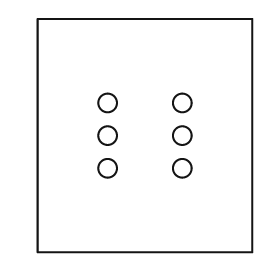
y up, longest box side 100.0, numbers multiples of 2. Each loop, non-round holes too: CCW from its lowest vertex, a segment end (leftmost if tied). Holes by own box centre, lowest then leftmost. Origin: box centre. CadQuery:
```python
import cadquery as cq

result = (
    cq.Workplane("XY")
    .moveTo(-46.0, -50.0)
    .lineTo(46.0, -50.0)
    .lineTo(46.0, 50.0)
    .lineTo(-46.0, 50.0)
    .close()
    .moveTo(-16.0, -14.0)
    .circle(4.0)
    .moveTo(16.0, -14.0)
    .circle(4.0)
    .moveTo(-16.0, 0.0)
    .circle(4.0)
    .moveTo(16.0, 0.0)
    .circle(4.0)
    .moveTo(-16.0, 14.0)
    .circle(4.0)
    .moveTo(16.0, 14.0)
    .circle(4.0)
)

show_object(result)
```